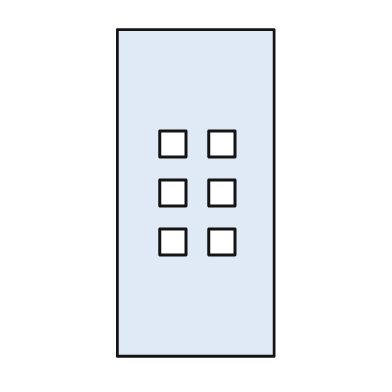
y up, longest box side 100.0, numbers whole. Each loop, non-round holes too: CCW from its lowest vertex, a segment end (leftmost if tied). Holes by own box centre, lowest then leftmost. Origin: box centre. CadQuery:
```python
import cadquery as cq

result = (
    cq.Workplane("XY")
    .moveTo(-24.0, -50.0)
    .lineTo(24.0, -50.0)
    .lineTo(24.0, 50.0)
    .lineTo(-24.0, 50.0)
    .close()
    .moveTo(-11.0, -19.0)
    .lineTo(-3.0, -19.0)
    .lineTo(-3.0, -11.0)
    .lineTo(-11.0, -11.0)
    .close()
    .moveTo(4.0, -19.0)
    .lineTo(12.0, -19.0)
    .lineTo(12.0, -11.0)
    .lineTo(4.0, -11.0)
    .close()
    .moveTo(-11.0, -4.0)
    .lineTo(-3.0, -4.0)
    .lineTo(-3.0, 4.0)
    .lineTo(-11.0, 4.0)
    .close()
    .moveTo(4.0, -4.0)
    .lineTo(12.0, -4.0)
    .lineTo(12.0, 4.0)
    .lineTo(4.0, 4.0)
    .close()
    .moveTo(-11.0, 11.0)
    .lineTo(-3.0, 11.0)
    .lineTo(-3.0, 19.0)
    .lineTo(-11.0, 19.0)
    .close()
    .moveTo(4.0, 11.0)
    .lineTo(12.0, 11.0)
    .lineTo(12.0, 19.0)
    .lineTo(4.0, 19.0)
    .close()
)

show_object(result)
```